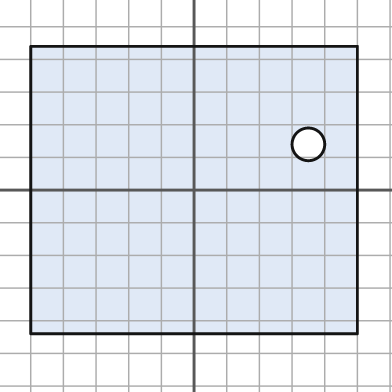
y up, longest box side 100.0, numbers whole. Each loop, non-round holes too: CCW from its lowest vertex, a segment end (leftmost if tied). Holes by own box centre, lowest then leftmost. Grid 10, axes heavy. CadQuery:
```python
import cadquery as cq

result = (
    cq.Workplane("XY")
    .moveTo(-50.0, -44.0)
    .lineTo(50.0, -44.0)
    .lineTo(50.0, 44.0)
    .lineTo(-50.0, 44.0)
    .close()
    .moveTo(35.0, 14.0)
    .circle(5.0)
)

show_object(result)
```